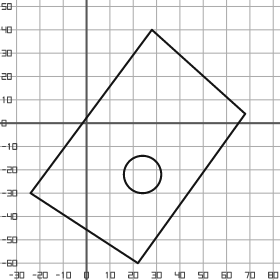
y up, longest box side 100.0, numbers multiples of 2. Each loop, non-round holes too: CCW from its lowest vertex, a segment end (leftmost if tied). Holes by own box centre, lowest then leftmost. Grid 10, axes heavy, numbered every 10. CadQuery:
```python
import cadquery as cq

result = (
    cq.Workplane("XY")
    .moveTo(22.0, -60.0)
    .lineTo(68.0, 4.0)
    .lineTo(28.0, 40.0)
    .lineTo(-24.0, -30.0)
    .close()
    .moveTo(24.0, -22.0)
    .circle(8.0)
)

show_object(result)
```